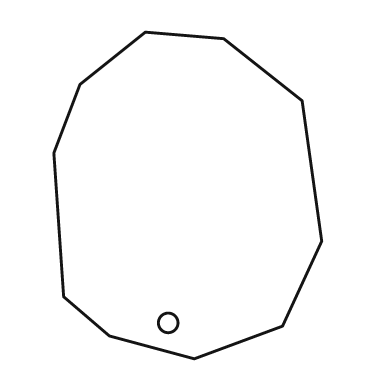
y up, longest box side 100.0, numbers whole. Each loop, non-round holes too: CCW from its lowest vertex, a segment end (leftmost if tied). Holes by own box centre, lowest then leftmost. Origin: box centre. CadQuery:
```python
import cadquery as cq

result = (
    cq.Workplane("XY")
    .moveTo(2.0, -50.0)
    .lineTo(29.0, -40.0)
    .lineTo(41.0, -14.0)
    .lineTo(35.0, 29.0)
    .lineTo(11.0, 48.0)
    .lineTo(-13.0, 50.0)
    .lineTo(-33.0, 34.0)
    .lineTo(-41.0, 13.0)
    .lineTo(-38.0, -31.0)
    .lineTo(-24.0, -43.0)
    .close()
    .moveTo(-6.0, -39.0)
    .circle(3.0)
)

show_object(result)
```